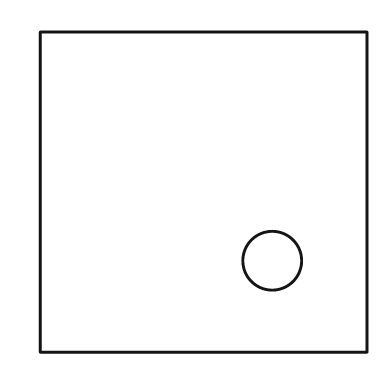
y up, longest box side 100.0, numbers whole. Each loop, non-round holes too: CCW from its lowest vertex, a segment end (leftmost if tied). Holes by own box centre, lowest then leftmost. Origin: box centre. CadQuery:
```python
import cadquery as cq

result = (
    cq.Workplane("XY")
    .moveTo(-50.0, -49.0)
    .lineTo(50.0, -49.0)
    .lineTo(50.0, 49.0)
    .lineTo(-50.0, 49.0)
    .close()
    .moveTo(21.0, -21.0)
    .circle(9.0)
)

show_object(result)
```